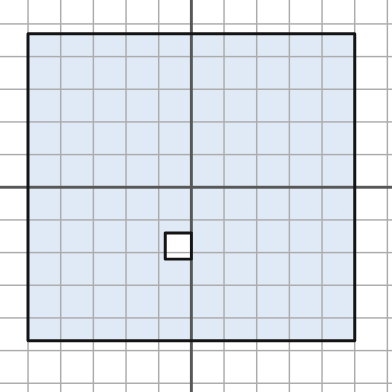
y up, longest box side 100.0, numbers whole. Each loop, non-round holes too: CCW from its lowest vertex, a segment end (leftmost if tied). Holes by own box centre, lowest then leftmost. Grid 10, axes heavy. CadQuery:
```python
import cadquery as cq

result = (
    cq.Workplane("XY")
    .moveTo(-50.0, -47.0)
    .lineTo(50.0, -47.0)
    .lineTo(50.0, 47.0)
    .lineTo(-50.0, 47.0)
    .close()
    .moveTo(-8.0, -22.0)
    .lineTo(0.0, -22.0)
    .lineTo(0.0, -14.0)
    .lineTo(-8.0, -14.0)
    .close()
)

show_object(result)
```